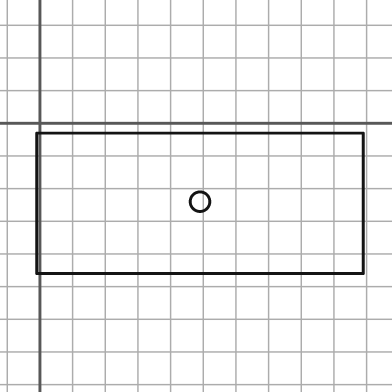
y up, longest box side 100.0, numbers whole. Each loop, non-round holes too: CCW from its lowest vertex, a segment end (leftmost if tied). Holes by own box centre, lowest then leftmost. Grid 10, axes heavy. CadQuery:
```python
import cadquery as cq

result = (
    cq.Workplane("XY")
    .moveTo(-1.0, -46.0)
    .lineTo(99.0, -46.0)
    .lineTo(99.0, -3.0)
    .lineTo(-1.0, -3.0)
    .close()
    .moveTo(49.0, -24.0)
    .circle(3.0)
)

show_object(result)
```